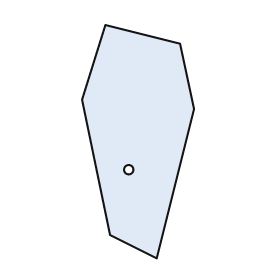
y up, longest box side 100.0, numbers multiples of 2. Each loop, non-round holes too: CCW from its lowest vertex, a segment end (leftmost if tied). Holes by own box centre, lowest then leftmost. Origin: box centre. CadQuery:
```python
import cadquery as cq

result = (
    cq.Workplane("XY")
    .moveTo(8.0, -50.0)
    .lineTo(24.0, 14.0)
    .lineTo(18.0, 42.0)
    .lineTo(-14.0, 50.0)
    .lineTo(-24.0, 18.0)
    .lineTo(-12.0, -40.0)
    .close()
    .moveTo(-4.0, -12.0)
    .circle(2.0)
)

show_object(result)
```